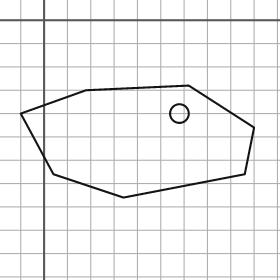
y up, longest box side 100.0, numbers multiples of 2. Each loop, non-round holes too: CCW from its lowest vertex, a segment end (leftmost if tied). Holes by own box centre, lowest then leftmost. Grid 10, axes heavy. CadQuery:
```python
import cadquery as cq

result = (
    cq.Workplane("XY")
    .moveTo(34.0, -76.0)
    .lineTo(86.0, -66.0)
    .lineTo(90.0, -46.0)
    .lineTo(62.0, -28.0)
    .lineTo(18.0, -30.0)
    .lineTo(-10.0, -40.0)
    .lineTo(4.0, -66.0)
    .close()
    .moveTo(58.0, -40.0)
    .circle(4.0)
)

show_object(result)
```